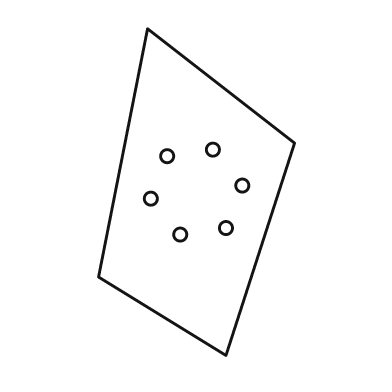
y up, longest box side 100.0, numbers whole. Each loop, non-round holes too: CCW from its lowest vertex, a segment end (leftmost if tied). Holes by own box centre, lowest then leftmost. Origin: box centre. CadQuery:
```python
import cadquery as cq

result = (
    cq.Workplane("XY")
    .moveTo(9.0, -50.0)
    .lineTo(30.0, 15.0)
    .lineTo(-15.0, 50.0)
    .lineTo(-30.0, -26.0)
    .close()
    .moveTo(-5.0, -13.0)
    .circle(2.0)
    .moveTo(9.0, -11.0)
    .circle(2.0)
    .moveTo(-14.0, -2.0)
    .circle(2.0)
    .moveTo(14.0, 2.0)
    .circle(2.0)
    .moveTo(-9.0, 11.0)
    .circle(2.0)
    .moveTo(5.0, 13.0)
    .circle(2.0)
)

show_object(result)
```